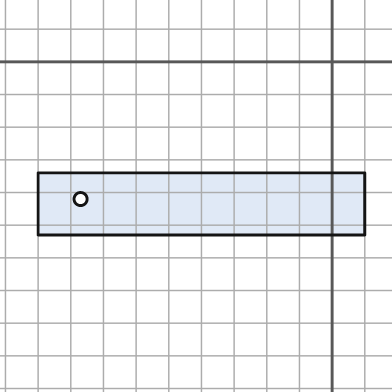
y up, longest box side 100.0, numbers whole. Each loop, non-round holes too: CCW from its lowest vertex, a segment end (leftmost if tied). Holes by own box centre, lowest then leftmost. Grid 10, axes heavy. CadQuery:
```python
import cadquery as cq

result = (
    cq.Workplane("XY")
    .moveTo(-90.0, -53.0)
    .lineTo(10.0, -53.0)
    .lineTo(10.0, -34.0)
    .lineTo(-90.0, -34.0)
    .close()
    .moveTo(-77.0, -42.0)
    .circle(2.0)
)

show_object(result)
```